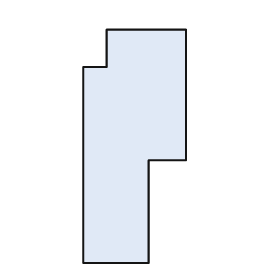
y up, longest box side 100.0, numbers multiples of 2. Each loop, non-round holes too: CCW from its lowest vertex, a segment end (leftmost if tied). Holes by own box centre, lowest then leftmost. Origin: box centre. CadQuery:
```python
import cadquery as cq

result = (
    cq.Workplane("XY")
    .moveTo(-22.0, -50.0)
    .lineTo(6.0, -50.0)
    .lineTo(6.0, -6.0)
    .lineTo(22.0, -6.0)
    .lineTo(22.0, 50.0)
    .lineTo(-12.0, 50.0)
    .lineTo(-12.0, 34.0)
    .lineTo(-22.0, 34.0)
    .close()
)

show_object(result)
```